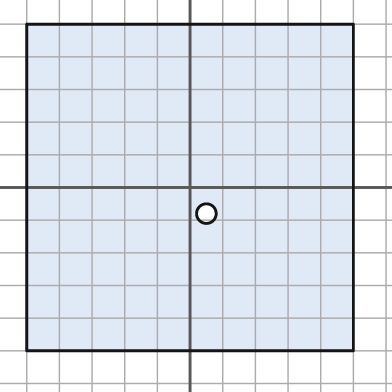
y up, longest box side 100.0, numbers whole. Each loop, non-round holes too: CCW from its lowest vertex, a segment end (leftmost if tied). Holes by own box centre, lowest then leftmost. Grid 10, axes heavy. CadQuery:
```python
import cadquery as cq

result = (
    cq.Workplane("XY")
    .moveTo(-50.0, -50.0)
    .lineTo(50.0, -50.0)
    .lineTo(50.0, 50.0)
    .lineTo(-50.0, 50.0)
    .close()
    .moveTo(5.0, -8.0)
    .circle(3.0)
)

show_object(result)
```